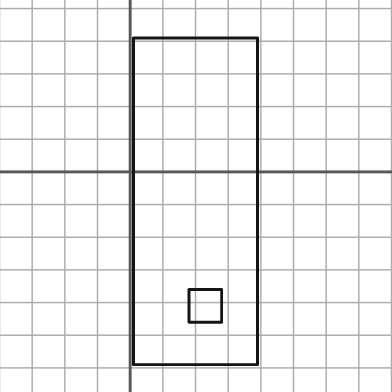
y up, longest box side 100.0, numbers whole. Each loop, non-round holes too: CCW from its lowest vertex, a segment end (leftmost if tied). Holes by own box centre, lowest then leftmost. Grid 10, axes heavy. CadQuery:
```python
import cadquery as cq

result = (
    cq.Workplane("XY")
    .moveTo(1.0, -59.0)
    .lineTo(39.0, -59.0)
    .lineTo(39.0, 41.0)
    .lineTo(1.0, 41.0)
    .close()
    .moveTo(18.0, -46.0)
    .lineTo(28.0, -46.0)
    .lineTo(28.0, -36.0)
    .lineTo(18.0, -36.0)
    .close()
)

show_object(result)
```